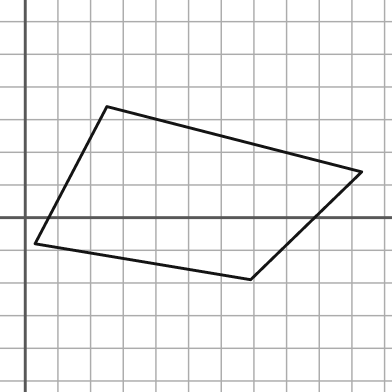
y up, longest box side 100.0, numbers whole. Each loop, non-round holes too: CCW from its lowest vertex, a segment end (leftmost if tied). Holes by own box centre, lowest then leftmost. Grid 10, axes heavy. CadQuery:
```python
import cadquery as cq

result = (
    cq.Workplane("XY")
    .moveTo(69.0, -19.0)
    .lineTo(103.0, 14.0)
    .lineTo(25.0, 34.0)
    .lineTo(3.0, -8.0)
    .close()
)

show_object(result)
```